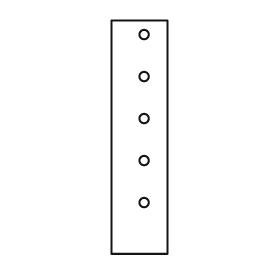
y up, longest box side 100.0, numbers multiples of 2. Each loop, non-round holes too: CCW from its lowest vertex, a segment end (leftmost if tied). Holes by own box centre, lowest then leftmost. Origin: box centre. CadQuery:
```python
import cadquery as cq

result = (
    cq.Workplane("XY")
    .moveTo(-12.0, -50.0)
    .lineTo(12.0, -50.0)
    .lineTo(12.0, 50.0)
    .lineTo(-12.0, 50.0)
    .close()
    .moveTo(2.0, -28.0)
    .circle(2.0)
    .moveTo(2.0, -10.0)
    .circle(2.0)
    .moveTo(2.0, 8.0)
    .circle(2.0)
    .moveTo(2.0, 26.0)
    .circle(2.0)
    .moveTo(2.0, 44.0)
    .circle(2.0)
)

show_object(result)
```